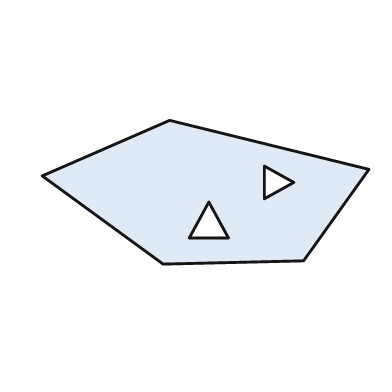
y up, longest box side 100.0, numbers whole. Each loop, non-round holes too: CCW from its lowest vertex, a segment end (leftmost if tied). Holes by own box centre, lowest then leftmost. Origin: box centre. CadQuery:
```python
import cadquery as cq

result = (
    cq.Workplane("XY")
    .moveTo(-13.0, -22.0)
    .lineTo(30.0, -21.0)
    .lineTo(50.0, 7.0)
    .lineTo(-11.0, 22.0)
    .lineTo(-50.0, 5.0)
    .close()
    .moveTo(-5.0, -14.0)
    .lineTo(7.0, -14.0)
    .lineTo(1.0, -3.0)
    .close()
    .moveTo(18.0, -2.0)
    .lineTo(27.0, 3.0)
    .lineTo(18.0, 8.0)
    .close()
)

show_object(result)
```